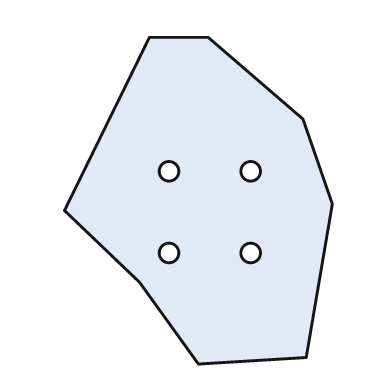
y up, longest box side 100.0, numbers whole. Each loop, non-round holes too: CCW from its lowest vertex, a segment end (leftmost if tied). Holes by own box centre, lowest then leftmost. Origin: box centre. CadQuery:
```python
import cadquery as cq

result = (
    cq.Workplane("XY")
    .moveTo(0.0, -50.0)
    .lineTo(33.0, -48.0)
    .lineTo(41.0, -1.0)
    .lineTo(32.0, 25.0)
    .lineTo(3.0, 50.0)
    .lineTo(-15.0, 50.0)
    .lineTo(-41.0, -3.0)
    .lineTo(-18.0, -25.0)
    .close()
    .moveTo(-9.0, -16.0)
    .circle(3.0)
    .moveTo(16.0, -16.0)
    .circle(3.0)
    .moveTo(-9.0, 9.0)
    .circle(3.0)
    .moveTo(16.0, 9.0)
    .circle(3.0)
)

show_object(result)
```